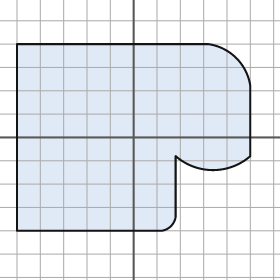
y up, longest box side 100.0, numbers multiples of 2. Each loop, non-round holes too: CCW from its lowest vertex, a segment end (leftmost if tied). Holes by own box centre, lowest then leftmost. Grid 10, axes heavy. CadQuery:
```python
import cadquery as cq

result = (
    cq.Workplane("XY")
    .moveTo(-50.0, -40.0)
    .lineTo(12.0, -40.0)
    .threePointArc((16.0, -38.0), (18.0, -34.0))
    .lineTo(18.0, -8.0)
    .threePointArc((34.0, -14.0), (50.0, -8.0))
    .lineTo(50.0, 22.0)
    .threePointArc((44.0, 34.0), (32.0, 40.0))
    .lineTo(-50.0, 40.0)
    .close()
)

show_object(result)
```